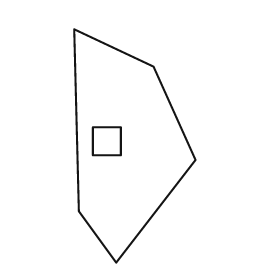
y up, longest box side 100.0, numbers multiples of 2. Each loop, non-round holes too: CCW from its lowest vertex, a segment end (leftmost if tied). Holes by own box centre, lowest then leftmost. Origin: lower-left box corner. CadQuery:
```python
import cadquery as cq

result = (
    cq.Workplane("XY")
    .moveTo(18.0, 0.0)
    .lineTo(52.0, 44.0)
    .lineTo(34.0, 84.0)
    .lineTo(0.0, 100.0)
    .lineTo(2.0, 22.0)
    .close()
    .moveTo(8.0, 46.0)
    .lineTo(20.0, 46.0)
    .lineTo(20.0, 58.0)
    .lineTo(8.0, 58.0)
    .close()
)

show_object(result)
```